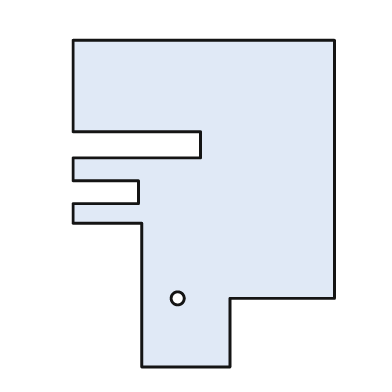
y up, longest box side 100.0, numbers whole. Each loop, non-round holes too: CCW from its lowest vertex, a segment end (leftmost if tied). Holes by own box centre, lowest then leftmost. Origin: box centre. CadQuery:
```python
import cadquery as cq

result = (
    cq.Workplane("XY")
    .moveTo(-19.0, -50.0)
    .lineTo(8.0, -50.0)
    .lineTo(8.0, -29.0)
    .lineTo(40.0, -29.0)
    .lineTo(40.0, 50.0)
    .lineTo(-40.0, 50.0)
    .lineTo(-40.0, 22.0)
    .lineTo(-1.0, 22.0)
    .lineTo(-1.0, 14.0)
    .lineTo(-40.0, 14.0)
    .lineTo(-40.0, 7.0)
    .lineTo(-20.0, 7.0)
    .lineTo(-20.0, 0.0)
    .lineTo(-40.0, 0.0)
    .lineTo(-40.0, -6.0)
    .lineTo(-19.0, -6.0)
    .close()
    .moveTo(-8.0, -29.0)
    .circle(2.0)
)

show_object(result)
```